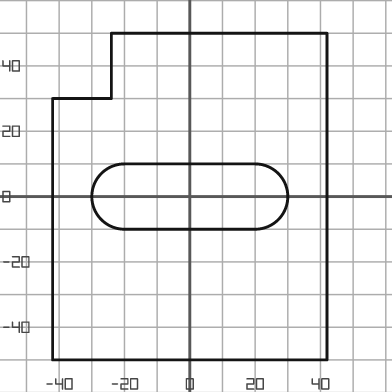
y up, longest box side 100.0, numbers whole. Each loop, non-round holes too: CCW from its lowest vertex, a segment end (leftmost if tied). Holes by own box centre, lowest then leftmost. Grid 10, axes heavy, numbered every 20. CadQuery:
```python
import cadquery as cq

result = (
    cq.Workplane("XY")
    .moveTo(-42.0, -50.0)
    .lineTo(42.0, -50.0)
    .lineTo(42.0, 50.0)
    .lineTo(-24.0, 50.0)
    .lineTo(-24.0, 30.0)
    .lineTo(-42.0, 30.0)
    .close()
    .moveTo(-20.0, -10.0)
    .lineTo(20.0, -10.0)
    .threePointArc((30.0, 0.0), (20.0, 10.0))
    .lineTo(-20.0, 10.0)
    .threePointArc((-30.0, 0.0), (-20.0, -10.0))
    .close()
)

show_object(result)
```